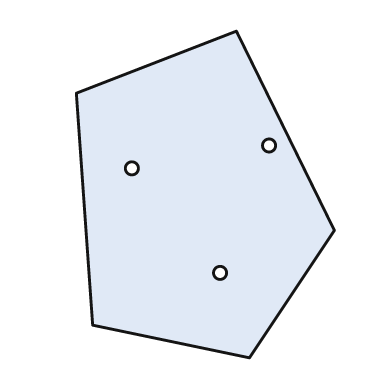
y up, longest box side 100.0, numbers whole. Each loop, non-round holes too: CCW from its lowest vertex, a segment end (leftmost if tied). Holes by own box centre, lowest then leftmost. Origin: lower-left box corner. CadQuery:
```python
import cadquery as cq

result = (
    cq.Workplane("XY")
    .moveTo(53.0, 0.0)
    .lineTo(79.0, 39.0)
    .lineTo(49.0, 100.0)
    .lineTo(0.0, 81.0)
    .lineTo(5.0, 10.0)
    .close()
    .moveTo(44.0, 26.0)
    .circle(2.0)
    .moveTo(17.0, 58.0)
    .circle(2.0)
    .moveTo(59.0, 65.0)
    .circle(2.0)
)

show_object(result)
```